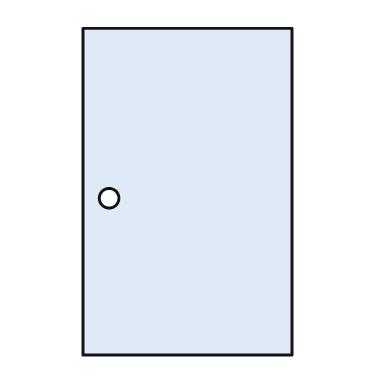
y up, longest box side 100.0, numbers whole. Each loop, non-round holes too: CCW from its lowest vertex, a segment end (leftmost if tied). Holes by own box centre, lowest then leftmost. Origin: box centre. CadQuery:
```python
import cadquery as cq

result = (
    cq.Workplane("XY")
    .moveTo(-32.0, -50.0)
    .lineTo(32.0, -50.0)
    .lineTo(32.0, 50.0)
    .lineTo(-32.0, 50.0)
    .close()
    .moveTo(-24.0, -2.0)
    .circle(3.0)
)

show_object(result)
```